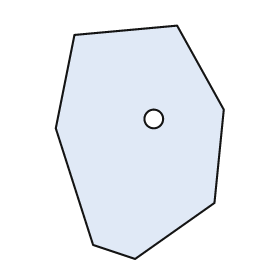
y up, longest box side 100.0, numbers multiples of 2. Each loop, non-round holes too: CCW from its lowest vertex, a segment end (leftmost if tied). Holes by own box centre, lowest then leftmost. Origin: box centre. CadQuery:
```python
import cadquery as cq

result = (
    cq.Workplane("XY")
    .moveTo(-2.0, -50.0)
    .lineTo(32.0, -26.0)
    .lineTo(36.0, 14.0)
    .lineTo(16.0, 50.0)
    .lineTo(-28.0, 46.0)
    .lineTo(-36.0, 6.0)
    .lineTo(-20.0, -44.0)
    .close()
    .moveTo(6.0, 10.0)
    .circle(4.0)
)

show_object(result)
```